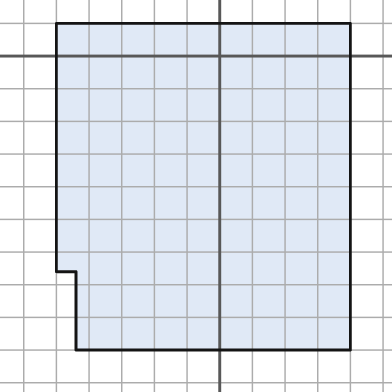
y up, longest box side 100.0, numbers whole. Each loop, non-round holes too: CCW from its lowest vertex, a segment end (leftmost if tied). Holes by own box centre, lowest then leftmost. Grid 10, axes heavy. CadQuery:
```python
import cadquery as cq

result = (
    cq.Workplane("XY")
    .moveTo(-44.0, -90.0)
    .lineTo(40.0, -90.0)
    .lineTo(40.0, 10.0)
    .lineTo(-50.0, 10.0)
    .lineTo(-50.0, -66.0)
    .lineTo(-44.0, -66.0)
    .close()
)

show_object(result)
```